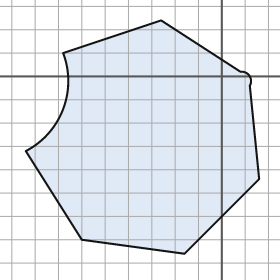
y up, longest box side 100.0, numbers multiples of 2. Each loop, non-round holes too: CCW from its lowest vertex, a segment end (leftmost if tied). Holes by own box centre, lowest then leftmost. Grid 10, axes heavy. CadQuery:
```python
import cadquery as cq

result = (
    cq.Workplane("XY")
    .moveTo(-16.0, -76.0)
    .lineTo(16.0, -44.0)
    .lineTo(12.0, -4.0)
    .threePointArc((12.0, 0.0), (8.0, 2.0))
    .lineTo(-26.0, 24.0)
    .lineTo(-68.0, 10.0)
    .threePointArc((-68.0, -14.0), (-84.0, -32.0))
    .lineTo(-60.0, -70.0)
    .close()
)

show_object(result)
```